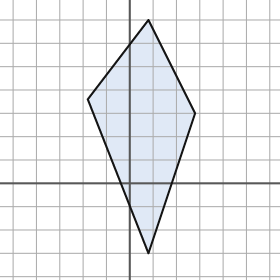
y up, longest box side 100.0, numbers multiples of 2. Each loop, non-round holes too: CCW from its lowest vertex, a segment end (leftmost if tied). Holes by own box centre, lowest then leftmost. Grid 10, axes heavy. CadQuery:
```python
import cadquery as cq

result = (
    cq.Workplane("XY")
    .moveTo(8.0, -30.0)
    .lineTo(28.0, 30.0)
    .lineTo(8.0, 70.0)
    .lineTo(-18.0, 36.0)
    .close()
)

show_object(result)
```